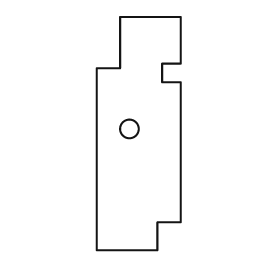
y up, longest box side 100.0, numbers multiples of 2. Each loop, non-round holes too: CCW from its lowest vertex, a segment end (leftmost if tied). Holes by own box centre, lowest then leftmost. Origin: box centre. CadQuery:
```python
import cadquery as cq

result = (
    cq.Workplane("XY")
    .moveTo(-18.0, -50.0)
    .lineTo(8.0, -50.0)
    .lineTo(8.0, -38.0)
    .lineTo(18.0, -38.0)
    .lineTo(18.0, 22.0)
    .lineTo(10.0, 22.0)
    .lineTo(10.0, 30.0)
    .lineTo(18.0, 30.0)
    .lineTo(18.0, 50.0)
    .lineTo(-8.0, 50.0)
    .lineTo(-8.0, 28.0)
    .lineTo(-18.0, 28.0)
    .close()
    .moveTo(-4.0, 2.0)
    .circle(4.0)
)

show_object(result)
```